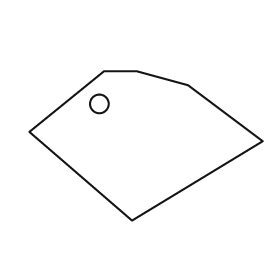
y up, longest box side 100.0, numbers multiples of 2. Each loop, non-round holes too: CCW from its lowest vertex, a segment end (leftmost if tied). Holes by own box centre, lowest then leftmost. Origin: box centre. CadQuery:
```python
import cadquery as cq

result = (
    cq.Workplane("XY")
    .moveTo(-6.0, -32.0)
    .lineTo(50.0, 2.0)
    .lineTo(18.0, 26.0)
    .lineTo(-4.0, 32.0)
    .lineTo(-18.0, 32.0)
    .lineTo(-50.0, 6.0)
    .close()
    .moveTo(-20.0, 18.0)
    .circle(4.0)
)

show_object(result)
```